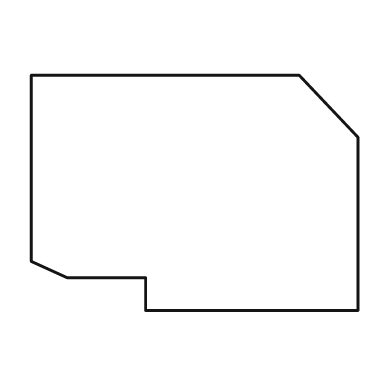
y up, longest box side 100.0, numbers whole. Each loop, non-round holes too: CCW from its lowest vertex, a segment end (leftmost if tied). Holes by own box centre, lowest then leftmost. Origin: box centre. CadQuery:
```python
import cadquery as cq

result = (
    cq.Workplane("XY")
    .moveTo(-15.0, -36.0)
    .lineTo(50.0, -36.0)
    .lineTo(50.0, 17.0)
    .lineTo(32.0, 36.0)
    .lineTo(-50.0, 36.0)
    .lineTo(-50.0, -21.0)
    .lineTo(-39.0, -26.0)
    .lineTo(-15.0, -26.0)
    .close()
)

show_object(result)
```